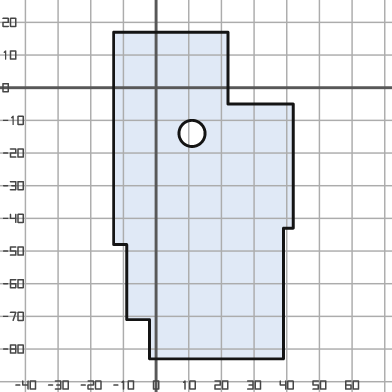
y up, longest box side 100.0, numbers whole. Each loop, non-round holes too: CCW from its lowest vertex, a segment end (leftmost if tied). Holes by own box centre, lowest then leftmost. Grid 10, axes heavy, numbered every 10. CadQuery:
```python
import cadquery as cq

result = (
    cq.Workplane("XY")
    .moveTo(-2.0, -83.0)
    .lineTo(39.0, -83.0)
    .lineTo(39.0, -43.0)
    .lineTo(42.0, -43.0)
    .lineTo(42.0, -5.0)
    .lineTo(22.0, -5.0)
    .lineTo(22.0, 17.0)
    .lineTo(-13.0, 17.0)
    .lineTo(-13.0, -48.0)
    .lineTo(-9.0, -48.0)
    .lineTo(-9.0, -71.0)
    .lineTo(-2.0, -71.0)
    .close()
    .moveTo(11.0, -14.0)
    .circle(4.0)
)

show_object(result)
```